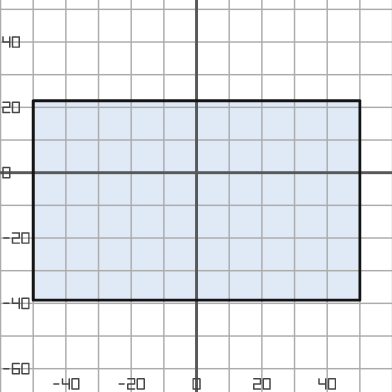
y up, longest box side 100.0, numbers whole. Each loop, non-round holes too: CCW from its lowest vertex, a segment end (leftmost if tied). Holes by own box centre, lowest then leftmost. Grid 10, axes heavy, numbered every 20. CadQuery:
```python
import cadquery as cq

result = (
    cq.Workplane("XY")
    .moveTo(-50.0, -39.0)
    .lineTo(50.0, -39.0)
    .lineTo(50.0, 22.0)
    .lineTo(-50.0, 22.0)
    .close()
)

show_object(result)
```